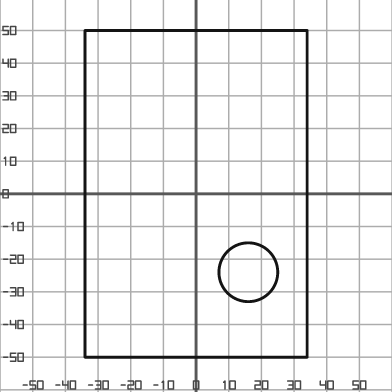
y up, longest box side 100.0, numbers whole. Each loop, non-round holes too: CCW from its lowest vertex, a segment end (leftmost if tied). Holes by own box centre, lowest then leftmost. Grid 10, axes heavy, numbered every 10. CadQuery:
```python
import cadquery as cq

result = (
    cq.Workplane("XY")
    .moveTo(-34.0, -50.0)
    .lineTo(34.0, -50.0)
    .lineTo(34.0, 50.0)
    .lineTo(-34.0, 50.0)
    .close()
    .moveTo(16.0, -24.0)
    .circle(9.0)
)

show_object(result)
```